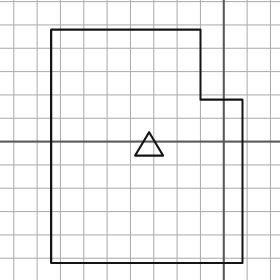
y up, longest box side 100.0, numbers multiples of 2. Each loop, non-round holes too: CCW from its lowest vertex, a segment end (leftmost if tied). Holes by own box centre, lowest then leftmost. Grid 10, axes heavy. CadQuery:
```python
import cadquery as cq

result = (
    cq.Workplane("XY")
    .moveTo(-74.0, -52.0)
    .lineTo(8.0, -52.0)
    .lineTo(8.0, 18.0)
    .lineTo(-10.0, 18.0)
    .lineTo(-10.0, 48.0)
    .lineTo(-74.0, 48.0)
    .close()
    .moveTo(-38.0, -6.0)
    .lineTo(-26.0, -6.0)
    .lineTo(-32.0, 4.0)
    .close()
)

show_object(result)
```